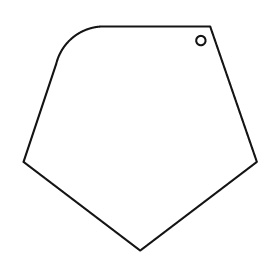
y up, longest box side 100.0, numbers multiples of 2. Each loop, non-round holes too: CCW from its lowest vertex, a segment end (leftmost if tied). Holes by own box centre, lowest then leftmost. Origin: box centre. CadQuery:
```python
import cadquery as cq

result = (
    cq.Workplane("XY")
    .moveTo(0.0, -48.0)
    .lineTo(50.0, -10.0)
    .lineTo(30.0, 48.0)
    .lineTo(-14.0, 48.0)
    .threePointArc((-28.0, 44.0), (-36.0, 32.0))
    .lineTo(-50.0, -10.0)
    .close()
    .moveTo(26.0, 42.0)
    .circle(2.0)
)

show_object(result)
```